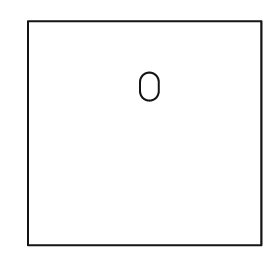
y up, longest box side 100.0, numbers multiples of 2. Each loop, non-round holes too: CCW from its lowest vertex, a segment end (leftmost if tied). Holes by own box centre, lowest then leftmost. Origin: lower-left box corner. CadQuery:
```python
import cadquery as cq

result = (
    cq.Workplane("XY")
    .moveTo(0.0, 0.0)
    .lineTo(100.0, 0.0)
    .lineTo(100.0, 96.0)
    .lineTo(0.0, 96.0)
    .close()
    .moveTo(48.0, 66.0)
    .threePointArc((52.0, 62.0), (56.0, 66.0))
    .lineTo(56.0, 70.0)
    .threePointArc((52.0, 74.0), (48.0, 70.0))
    .close()
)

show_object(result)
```